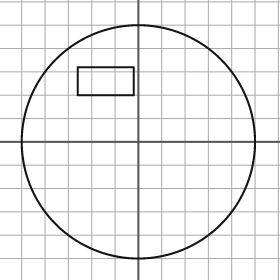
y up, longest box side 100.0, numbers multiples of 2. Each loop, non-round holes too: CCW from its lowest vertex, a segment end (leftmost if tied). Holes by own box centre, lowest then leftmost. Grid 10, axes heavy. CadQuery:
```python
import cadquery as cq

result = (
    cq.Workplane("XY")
    .moveTo(0.0, 0.0)
    .circle(50.0)
    .moveTo(-26.0, 20.0)
    .lineTo(-2.0, 20.0)
    .lineTo(-2.0, 32.0)
    .lineTo(-26.0, 32.0)
    .close()
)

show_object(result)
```